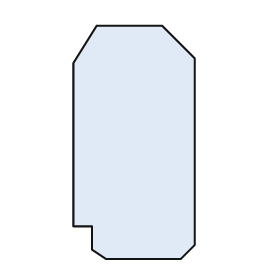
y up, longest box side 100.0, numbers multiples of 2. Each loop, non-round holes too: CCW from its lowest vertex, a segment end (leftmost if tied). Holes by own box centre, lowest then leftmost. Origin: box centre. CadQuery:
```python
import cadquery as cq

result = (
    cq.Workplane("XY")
    .moveTo(-12.0, -50.0)
    .lineTo(20.0, -50.0)
    .lineTo(26.0, -44.0)
    .lineTo(26.0, 36.0)
    .lineTo(12.0, 50.0)
    .lineTo(-16.0, 50.0)
    .lineTo(-26.0, 34.0)
    .lineTo(-26.0, -36.0)
    .lineTo(-18.0, -36.0)
    .lineTo(-18.0, -46.0)
    .close()
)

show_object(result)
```